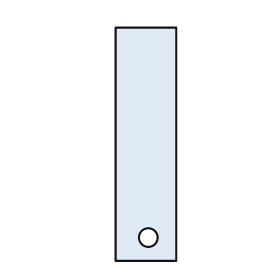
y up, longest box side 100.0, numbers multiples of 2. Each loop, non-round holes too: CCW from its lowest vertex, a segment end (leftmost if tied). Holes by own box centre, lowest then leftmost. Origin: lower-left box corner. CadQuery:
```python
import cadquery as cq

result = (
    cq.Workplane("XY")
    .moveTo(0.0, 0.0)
    .lineTo(26.0, 0.0)
    .lineTo(26.0, 100.0)
    .lineTo(0.0, 100.0)
    .close()
    .moveTo(14.0, 10.0)
    .circle(4.0)
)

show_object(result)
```